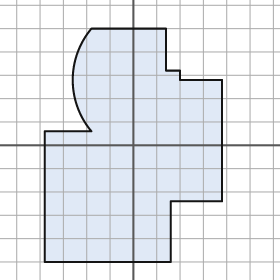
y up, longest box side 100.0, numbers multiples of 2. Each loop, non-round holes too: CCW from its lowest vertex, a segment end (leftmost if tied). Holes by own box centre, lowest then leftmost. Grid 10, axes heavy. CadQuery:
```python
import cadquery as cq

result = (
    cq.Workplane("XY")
    .moveTo(-38.0, -50.0)
    .lineTo(16.0, -50.0)
    .lineTo(16.0, -24.0)
    .lineTo(38.0, -24.0)
    .lineTo(38.0, 28.0)
    .lineTo(20.0, 28.0)
    .lineTo(20.0, 32.0)
    .lineTo(14.0, 32.0)
    .lineTo(14.0, 50.0)
    .lineTo(-18.0, 50.0)
    .threePointArc((-26.0, 28.0), (-18.0, 6.0))
    .lineTo(-38.0, 6.0)
    .close()
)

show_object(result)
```